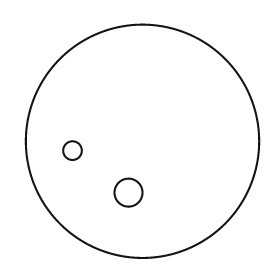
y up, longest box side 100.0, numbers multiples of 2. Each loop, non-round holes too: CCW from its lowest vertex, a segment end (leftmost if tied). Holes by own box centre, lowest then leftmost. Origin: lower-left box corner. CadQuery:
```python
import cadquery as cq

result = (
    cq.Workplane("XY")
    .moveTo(50.0, 50.0)
    .circle(50.0)
    .moveTo(44.0, 28.0)
    .circle(6.0)
    .moveTo(20.0, 46.0)
    .circle(4.0)
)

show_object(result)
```